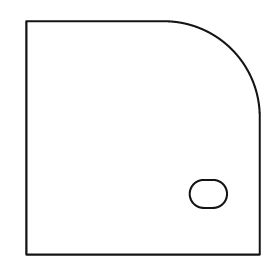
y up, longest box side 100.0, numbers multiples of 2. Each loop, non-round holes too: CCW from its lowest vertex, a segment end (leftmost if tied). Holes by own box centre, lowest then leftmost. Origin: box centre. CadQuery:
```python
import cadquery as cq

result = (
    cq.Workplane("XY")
    .moveTo(-50.0, -50.0)
    .lineTo(50.0, -50.0)
    .lineTo(50.0, 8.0)
    .threePointArc((38.0, 38.0), (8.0, 50.0))
    .lineTo(-50.0, 50.0)
    .close()
    .moveTo(26.0, -30.0)
    .lineTo(30.0, -30.0)
    .threePointArc((36.0, -24.0), (30.0, -18.0))
    .lineTo(26.0, -18.0)
    .threePointArc((20.0, -24.0), (26.0, -30.0))
    .close()
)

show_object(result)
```